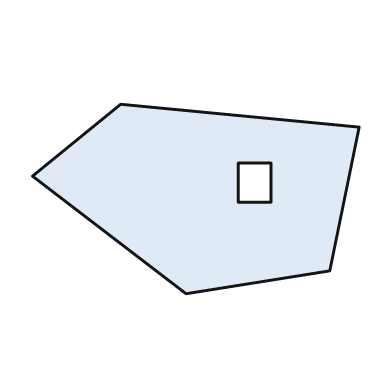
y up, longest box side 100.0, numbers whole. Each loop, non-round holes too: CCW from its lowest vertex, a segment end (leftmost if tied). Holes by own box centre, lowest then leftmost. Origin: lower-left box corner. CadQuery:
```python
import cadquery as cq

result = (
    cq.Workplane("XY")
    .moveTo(47.0, 0.0)
    .lineTo(91.0, 7.0)
    .lineTo(100.0, 51.0)
    .lineTo(27.0, 58.0)
    .lineTo(0.0, 36.0)
    .close()
    .moveTo(63.0, 28.0)
    .lineTo(73.0, 28.0)
    .lineTo(73.0, 40.0)
    .lineTo(63.0, 40.0)
    .close()
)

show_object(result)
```